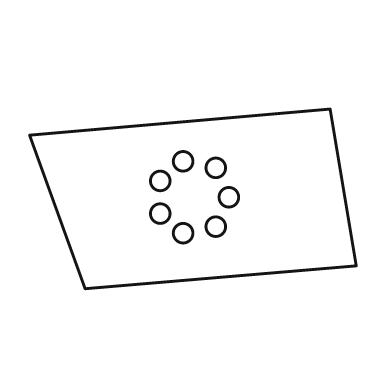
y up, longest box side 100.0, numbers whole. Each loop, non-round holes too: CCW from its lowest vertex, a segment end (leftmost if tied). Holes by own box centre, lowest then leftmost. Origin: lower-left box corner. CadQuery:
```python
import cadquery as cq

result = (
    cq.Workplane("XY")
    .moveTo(17.0, 0.0)
    .lineTo(100.0, 7.0)
    .lineTo(92.0, 55.0)
    .lineTo(0.0, 47.0)
    .close()
    .moveTo(47.0, 17.0)
    .circle(3.0)
    .moveTo(57.0, 19.0)
    .circle(3.0)
    .moveTo(40.0, 23.0)
    .circle(3.0)
    .moveTo(61.0, 28.0)
    .circle(3.0)
    .moveTo(40.0, 33.0)
    .circle(3.0)
    .moveTo(57.0, 37.0)
    .circle(3.0)
    .moveTo(47.0, 39.0)
    .circle(3.0)
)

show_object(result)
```